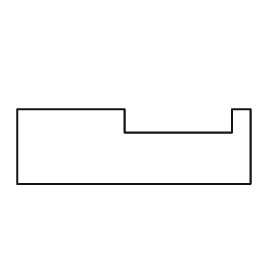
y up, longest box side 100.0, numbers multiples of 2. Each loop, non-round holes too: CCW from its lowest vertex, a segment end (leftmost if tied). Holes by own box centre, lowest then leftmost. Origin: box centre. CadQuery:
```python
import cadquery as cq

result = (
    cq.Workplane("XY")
    .moveTo(-50.0, -16.0)
    .lineTo(50.0, -16.0)
    .lineTo(50.0, 16.0)
    .lineTo(42.0, 16.0)
    .lineTo(42.0, 6.0)
    .lineTo(-4.0, 6.0)
    .lineTo(-4.0, 16.0)
    .lineTo(-50.0, 16.0)
    .close()
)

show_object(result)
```